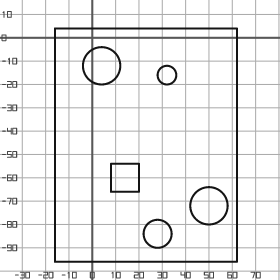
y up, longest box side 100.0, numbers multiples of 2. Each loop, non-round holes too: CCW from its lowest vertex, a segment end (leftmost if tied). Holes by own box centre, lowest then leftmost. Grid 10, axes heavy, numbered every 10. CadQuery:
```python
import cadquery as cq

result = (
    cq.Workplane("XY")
    .moveTo(-16.0, -96.0)
    .lineTo(62.0, -96.0)
    .lineTo(62.0, 4.0)
    .lineTo(-16.0, 4.0)
    .close()
    .moveTo(28.0, -84.0)
    .circle(6.0)
    .moveTo(50.0, -72.0)
    .circle(8.0)
    .moveTo(8.0, -66.0)
    .lineTo(20.0, -66.0)
    .lineTo(20.0, -54.0)
    .lineTo(8.0, -54.0)
    .close()
    .moveTo(32.0, -16.0)
    .circle(4.0)
    .moveTo(4.0, -12.0)
    .circle(8.0)
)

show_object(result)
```